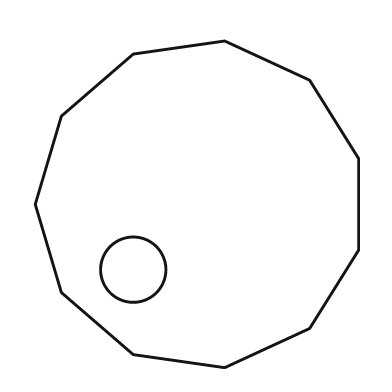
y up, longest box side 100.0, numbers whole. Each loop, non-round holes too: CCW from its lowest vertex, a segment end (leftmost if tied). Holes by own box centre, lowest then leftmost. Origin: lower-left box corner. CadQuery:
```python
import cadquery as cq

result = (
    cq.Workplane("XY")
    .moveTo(58.0, 0.0)
    .lineTo(84.0, 12.0)
    .lineTo(99.0, 36.0)
    .lineTo(99.0, 64.0)
    .lineTo(84.0, 88.0)
    .lineTo(58.0, 100.0)
    .lineTo(30.0, 96.0)
    .lineTo(8.0, 77.0)
    .lineTo(0.0, 50.0)
    .lineTo(8.0, 23.0)
    .lineTo(30.0, 4.0)
    .close()
    .moveTo(30.0, 30.0)
    .circle(10.0)
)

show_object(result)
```